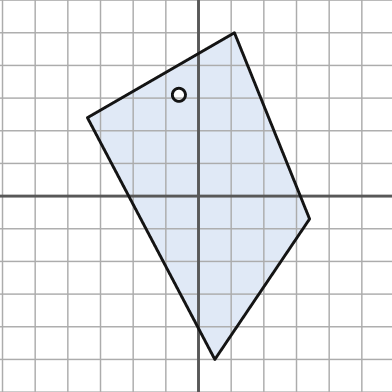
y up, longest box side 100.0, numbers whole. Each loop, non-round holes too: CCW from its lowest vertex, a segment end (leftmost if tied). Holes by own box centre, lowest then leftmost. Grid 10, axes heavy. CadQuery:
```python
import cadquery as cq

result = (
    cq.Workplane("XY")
    .moveTo(5.0, -50.0)
    .lineTo(34.0, -7.0)
    .lineTo(11.0, 50.0)
    .lineTo(-34.0, 24.0)
    .close()
    .moveTo(-6.0, 31.0)
    .circle(2.0)
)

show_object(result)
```